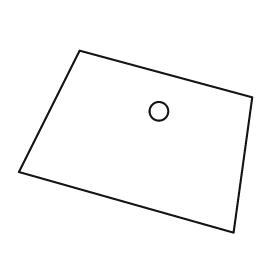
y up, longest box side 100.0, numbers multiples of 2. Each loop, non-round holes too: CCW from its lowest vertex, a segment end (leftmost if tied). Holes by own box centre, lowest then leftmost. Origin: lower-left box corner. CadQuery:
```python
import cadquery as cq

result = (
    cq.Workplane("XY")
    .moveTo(92.0, 0.0)
    .lineTo(100.0, 58.0)
    .lineTo(26.0, 78.0)
    .lineTo(0.0, 26.0)
    .close()
    .moveTo(60.0, 52.0)
    .circle(4.0)
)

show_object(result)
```